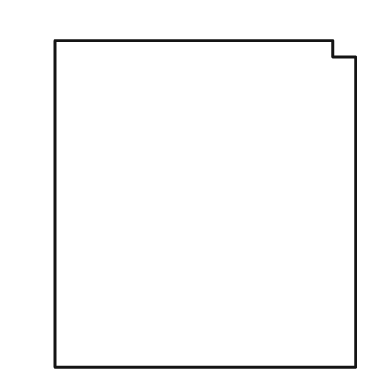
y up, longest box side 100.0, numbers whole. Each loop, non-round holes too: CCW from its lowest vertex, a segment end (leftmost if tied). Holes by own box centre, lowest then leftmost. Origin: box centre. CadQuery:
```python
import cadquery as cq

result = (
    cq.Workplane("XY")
    .moveTo(-46.0, -50.0)
    .lineTo(46.0, -50.0)
    .lineTo(46.0, 45.0)
    .lineTo(39.0, 45.0)
    .lineTo(39.0, 50.0)
    .lineTo(-46.0, 50.0)
    .close()
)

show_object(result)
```